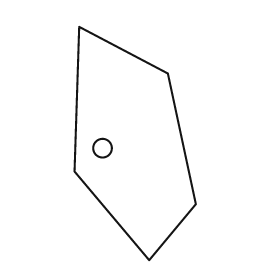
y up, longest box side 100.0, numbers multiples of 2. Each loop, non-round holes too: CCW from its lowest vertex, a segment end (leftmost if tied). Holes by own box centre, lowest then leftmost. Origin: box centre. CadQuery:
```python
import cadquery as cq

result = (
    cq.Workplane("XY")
    .moveTo(6.0, -50.0)
    .lineTo(26.0, -26.0)
    .lineTo(14.0, 30.0)
    .lineTo(-24.0, 50.0)
    .lineTo(-26.0, -12.0)
    .close()
    .moveTo(-14.0, -2.0)
    .circle(4.0)
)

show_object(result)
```